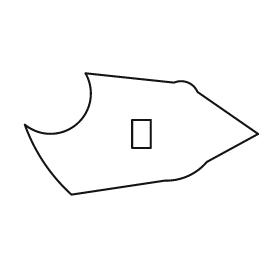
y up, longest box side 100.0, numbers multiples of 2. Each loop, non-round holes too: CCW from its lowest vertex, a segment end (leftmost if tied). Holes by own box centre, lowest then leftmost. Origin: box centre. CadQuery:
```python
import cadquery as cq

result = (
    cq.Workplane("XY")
    .moveTo(-30.0, -26.0)
    .lineTo(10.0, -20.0)
    .threePointArc((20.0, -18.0), (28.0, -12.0))
    .lineTo(50.0, 0.0)
    .lineTo(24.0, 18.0)
    .threePointArc((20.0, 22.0), (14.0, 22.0))
    .lineTo(-24.0, 26.0)
    .threePointArc((-28.0, 4.0), (-50.0, 4.0))
    .threePointArc((-42.0, -12.0), (-30.0, -26.0))
    .close()
    .moveTo(-4.0, -6.0)
    .lineTo(4.0, -6.0)
    .lineTo(4.0, 6.0)
    .lineTo(-4.0, 6.0)
    .close()
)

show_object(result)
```